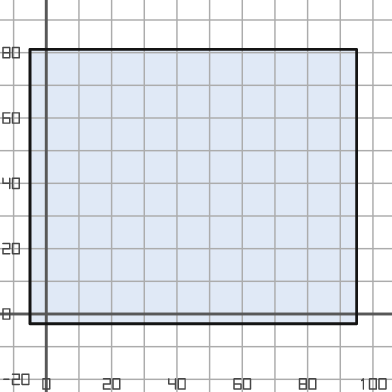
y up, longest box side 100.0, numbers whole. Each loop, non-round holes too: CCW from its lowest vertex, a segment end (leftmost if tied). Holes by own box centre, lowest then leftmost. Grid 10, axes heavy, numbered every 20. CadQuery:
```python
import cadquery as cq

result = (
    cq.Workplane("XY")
    .moveTo(-5.0, -3.0)
    .lineTo(95.0, -3.0)
    .lineTo(95.0, 81.0)
    .lineTo(-5.0, 81.0)
    .close()
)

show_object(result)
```